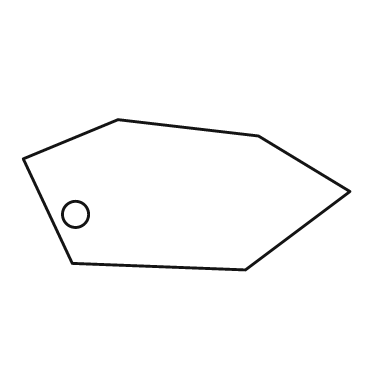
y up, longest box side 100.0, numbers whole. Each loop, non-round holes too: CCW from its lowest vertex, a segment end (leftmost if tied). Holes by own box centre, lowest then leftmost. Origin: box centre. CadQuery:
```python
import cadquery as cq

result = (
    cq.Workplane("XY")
    .moveTo(18.0, -23.0)
    .lineTo(50.0, 1.0)
    .lineTo(22.0, 18.0)
    .lineTo(-21.0, 23.0)
    .lineTo(-50.0, 11.0)
    .lineTo(-35.0, -21.0)
    .close()
    .moveTo(-34.0, -6.0)
    .circle(4.0)
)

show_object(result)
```